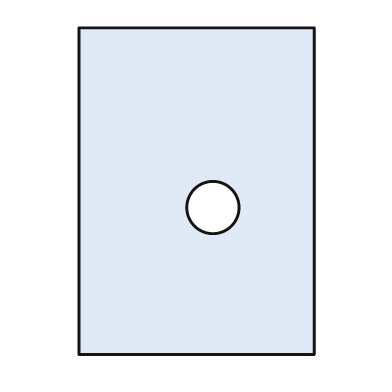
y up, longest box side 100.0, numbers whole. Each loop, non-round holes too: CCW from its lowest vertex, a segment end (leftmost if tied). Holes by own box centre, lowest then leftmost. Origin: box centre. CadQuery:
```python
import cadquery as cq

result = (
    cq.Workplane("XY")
    .moveTo(-36.0, -50.0)
    .lineTo(36.0, -50.0)
    .lineTo(36.0, 50.0)
    .lineTo(-36.0, 50.0)
    .close()
    .moveTo(5.0, -5.0)
    .circle(8.0)
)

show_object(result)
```